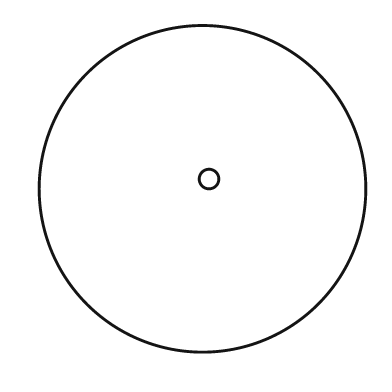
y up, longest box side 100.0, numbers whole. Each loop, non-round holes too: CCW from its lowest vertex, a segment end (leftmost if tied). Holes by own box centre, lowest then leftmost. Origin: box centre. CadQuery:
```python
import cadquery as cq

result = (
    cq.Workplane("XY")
    .moveTo(0.0, 0.0)
    .circle(50.0)
    .moveTo(2.0, 3.0)
    .circle(3.0)
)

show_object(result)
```